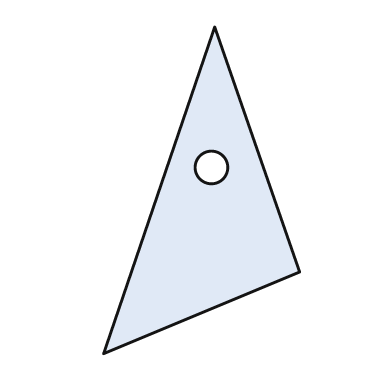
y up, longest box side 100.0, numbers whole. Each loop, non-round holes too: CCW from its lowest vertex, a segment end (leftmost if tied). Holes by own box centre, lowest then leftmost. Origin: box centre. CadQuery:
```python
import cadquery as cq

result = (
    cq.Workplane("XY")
    .moveTo(-30.0, -50.0)
    .lineTo(30.0, -25.0)
    .lineTo(4.0, 50.0)
    .close()
    .moveTo(3.0, 7.0)
    .circle(5.0)
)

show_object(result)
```